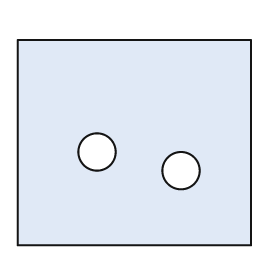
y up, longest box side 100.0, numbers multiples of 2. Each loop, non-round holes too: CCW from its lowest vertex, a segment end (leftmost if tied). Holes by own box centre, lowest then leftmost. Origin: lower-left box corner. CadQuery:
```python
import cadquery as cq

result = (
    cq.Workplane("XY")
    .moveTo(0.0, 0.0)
    .lineTo(100.0, 0.0)
    .lineTo(100.0, 88.0)
    .lineTo(0.0, 88.0)
    .close()
    .moveTo(70.0, 32.0)
    .circle(8.0)
    .moveTo(34.0, 40.0)
    .circle(8.0)
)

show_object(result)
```